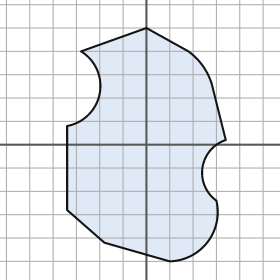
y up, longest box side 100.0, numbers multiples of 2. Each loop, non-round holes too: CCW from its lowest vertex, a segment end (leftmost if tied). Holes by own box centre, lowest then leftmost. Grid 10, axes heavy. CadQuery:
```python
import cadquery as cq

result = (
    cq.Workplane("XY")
    .moveTo(10.0, -50.0)
    .threePointArc((26.0, -42.0), (30.0, -24.0))
    .threePointArc((24.0, -10.0), (34.0, 2.0))
    .lineTo(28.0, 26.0)
    .threePointArc((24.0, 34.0), (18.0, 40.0))
    .lineTo(0.0, 50.0)
    .lineTo(-28.0, 40.0)
    .threePointArc((-20.0, 22.0), (-34.0, 8.0))
    .lineTo(-34.0, -28.0)
    .lineTo(-18.0, -42.0)
    .close()
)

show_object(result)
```